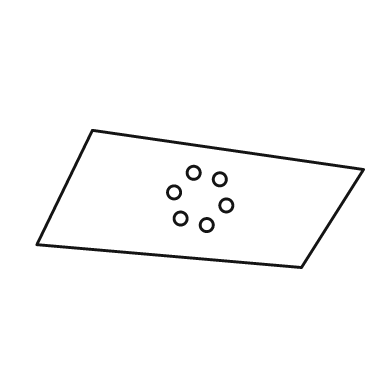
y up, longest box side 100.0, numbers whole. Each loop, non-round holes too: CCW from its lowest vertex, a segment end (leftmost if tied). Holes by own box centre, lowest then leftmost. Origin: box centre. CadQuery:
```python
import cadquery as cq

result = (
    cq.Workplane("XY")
    .moveTo(31.0, -21.0)
    .lineTo(50.0, 9.0)
    .lineTo(-33.0, 21.0)
    .lineTo(-50.0, -14.0)
    .close()
    .moveTo(2.0, -8.0)
    .circle(2.0)
    .moveTo(-6.0, -6.0)
    .circle(2.0)
    .moveTo(8.0, -2.0)
    .circle(2.0)
    .moveTo(-8.0, 2.0)
    .circle(2.0)
    .moveTo(6.0, 6.0)
    .circle(2.0)
    .moveTo(-2.0, 8.0)
    .circle(2.0)
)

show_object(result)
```